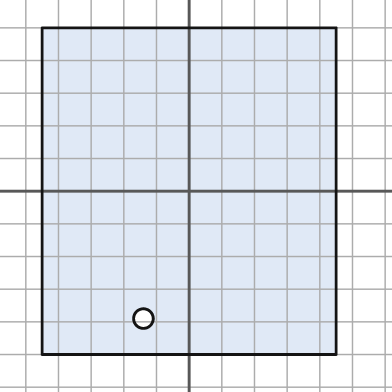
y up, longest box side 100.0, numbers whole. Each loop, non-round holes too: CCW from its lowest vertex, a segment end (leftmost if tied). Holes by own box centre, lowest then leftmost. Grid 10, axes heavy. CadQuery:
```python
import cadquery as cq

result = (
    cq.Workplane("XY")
    .moveTo(-45.0, -50.0)
    .lineTo(45.0, -50.0)
    .lineTo(45.0, 50.0)
    .lineTo(-45.0, 50.0)
    .close()
    .moveTo(-14.0, -39.0)
    .circle(3.0)
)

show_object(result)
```